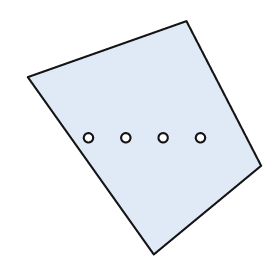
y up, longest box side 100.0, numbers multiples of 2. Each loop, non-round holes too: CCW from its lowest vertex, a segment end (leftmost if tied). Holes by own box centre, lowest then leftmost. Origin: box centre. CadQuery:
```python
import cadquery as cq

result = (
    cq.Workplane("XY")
    .moveTo(4.0, -50.0)
    .lineTo(50.0, -12.0)
    .lineTo(18.0, 50.0)
    .lineTo(-50.0, 26.0)
    .close()
    .moveTo(-24.0, 0.0)
    .circle(2.0)
    .moveTo(-8.0, 0.0)
    .circle(2.0)
    .moveTo(8.0, 0.0)
    .circle(2.0)
    .moveTo(24.0, 0.0)
    .circle(2.0)
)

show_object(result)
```